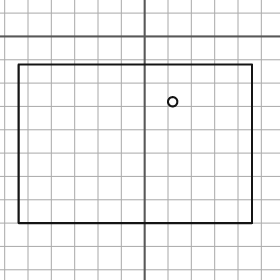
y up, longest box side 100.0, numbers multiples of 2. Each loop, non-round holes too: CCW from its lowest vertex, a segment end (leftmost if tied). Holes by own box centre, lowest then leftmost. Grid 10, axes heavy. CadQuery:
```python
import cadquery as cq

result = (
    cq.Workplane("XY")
    .moveTo(-54.0, -80.0)
    .lineTo(46.0, -80.0)
    .lineTo(46.0, -12.0)
    .lineTo(-54.0, -12.0)
    .close()
    .moveTo(12.0, -28.0)
    .circle(2.0)
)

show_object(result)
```